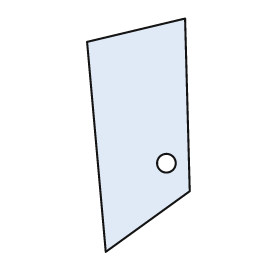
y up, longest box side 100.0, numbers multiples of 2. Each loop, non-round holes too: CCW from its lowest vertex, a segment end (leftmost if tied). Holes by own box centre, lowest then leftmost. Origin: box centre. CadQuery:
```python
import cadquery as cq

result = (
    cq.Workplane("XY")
    .moveTo(-14.0, -50.0)
    .lineTo(22.0, -24.0)
    .lineTo(20.0, 50.0)
    .lineTo(-22.0, 40.0)
    .close()
    .moveTo(12.0, -12.0)
    .circle(4.0)
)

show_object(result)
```